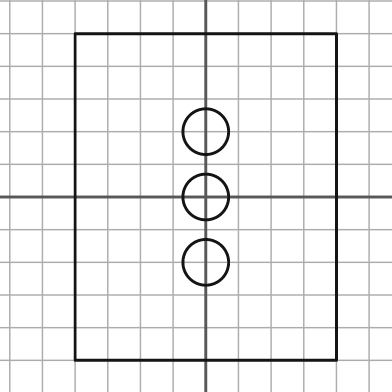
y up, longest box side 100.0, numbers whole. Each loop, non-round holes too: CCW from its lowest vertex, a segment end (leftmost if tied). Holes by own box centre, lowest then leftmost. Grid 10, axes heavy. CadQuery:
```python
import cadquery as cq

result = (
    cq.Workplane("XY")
    .moveTo(-40.0, -50.0)
    .lineTo(40.0, -50.0)
    .lineTo(40.0, 50.0)
    .lineTo(-40.0, 50.0)
    .close()
    .moveTo(0.0, -20.0)
    .circle(7.0)
    .moveTo(0.0, 0.0)
    .circle(7.0)
    .moveTo(0.0, 20.0)
    .circle(7.0)
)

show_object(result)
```